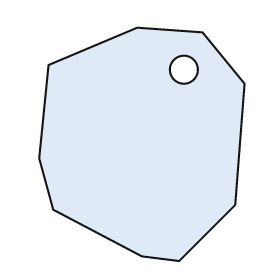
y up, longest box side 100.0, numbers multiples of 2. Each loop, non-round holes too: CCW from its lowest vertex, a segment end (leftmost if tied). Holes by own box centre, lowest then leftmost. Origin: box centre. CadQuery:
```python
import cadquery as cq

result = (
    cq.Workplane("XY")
    .moveTo(16.0, -50.0)
    .lineTo(40.0, -26.0)
    .lineTo(44.0, 26.0)
    .lineTo(26.0, 48.0)
    .lineTo(-2.0, 50.0)
    .lineTo(-40.0, 34.0)
    .lineTo(-44.0, -6.0)
    .lineTo(-38.0, -28.0)
    .lineTo(0.0, -48.0)
    .close()
    .moveTo(18.0, 32.0)
    .circle(6.0)
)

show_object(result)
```